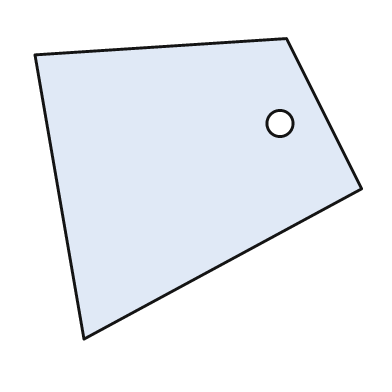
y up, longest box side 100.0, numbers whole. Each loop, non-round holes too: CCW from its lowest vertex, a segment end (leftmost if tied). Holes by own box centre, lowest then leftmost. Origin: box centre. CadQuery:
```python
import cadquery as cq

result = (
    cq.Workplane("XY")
    .moveTo(-35.0, -46.0)
    .lineTo(50.0, 0.0)
    .lineTo(27.0, 46.0)
    .lineTo(-50.0, 41.0)
    .close()
    .moveTo(25.0, 20.0)
    .circle(4.0)
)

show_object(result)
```